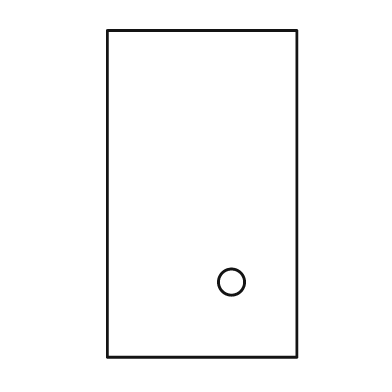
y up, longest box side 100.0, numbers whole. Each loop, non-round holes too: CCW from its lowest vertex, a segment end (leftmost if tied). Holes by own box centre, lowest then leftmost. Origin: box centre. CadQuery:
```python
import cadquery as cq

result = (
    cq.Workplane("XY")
    .moveTo(-29.0, -50.0)
    .lineTo(29.0, -50.0)
    .lineTo(29.0, 50.0)
    .lineTo(-29.0, 50.0)
    .close()
    .moveTo(9.0, -27.0)
    .circle(4.0)
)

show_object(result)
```